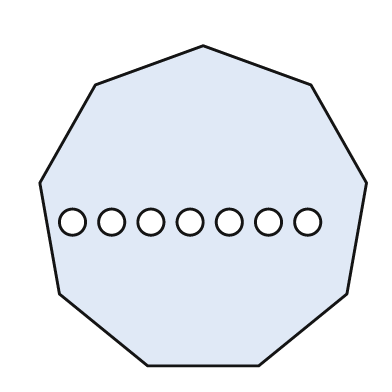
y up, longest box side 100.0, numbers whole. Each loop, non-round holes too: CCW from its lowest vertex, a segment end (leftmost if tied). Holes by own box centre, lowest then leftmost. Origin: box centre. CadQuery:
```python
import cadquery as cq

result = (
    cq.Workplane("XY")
    .moveTo(-17.0, -49.0)
    .lineTo(17.0, -49.0)
    .lineTo(44.0, -27.0)
    .lineTo(50.0, 7.0)
    .lineTo(33.0, 37.0)
    .lineTo(0.0, 49.0)
    .lineTo(-33.0, 37.0)
    .lineTo(-50.0, 7.0)
    .lineTo(-44.0, -27.0)
    .close()
    .moveTo(-40.0, -5.0)
    .circle(4.0)
    .moveTo(-28.0, -5.0)
    .circle(4.0)
    .moveTo(-16.0, -5.0)
    .circle(4.0)
    .moveTo(-4.0, -5.0)
    .circle(4.0)
    .moveTo(8.0, -5.0)
    .circle(4.0)
    .moveTo(20.0, -5.0)
    .circle(4.0)
    .moveTo(32.0, -5.0)
    .circle(4.0)
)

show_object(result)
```